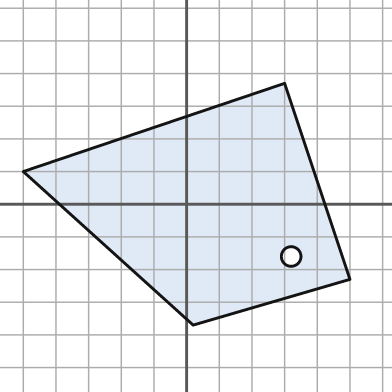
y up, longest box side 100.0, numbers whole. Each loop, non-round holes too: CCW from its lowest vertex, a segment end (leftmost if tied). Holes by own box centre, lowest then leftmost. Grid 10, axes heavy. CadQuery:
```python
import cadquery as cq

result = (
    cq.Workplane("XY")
    .moveTo(2.0, -37.0)
    .lineTo(50.0, -23.0)
    .lineTo(30.0, 37.0)
    .lineTo(-50.0, 10.0)
    .close()
    .moveTo(32.0, -16.0)
    .circle(3.0)
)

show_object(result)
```